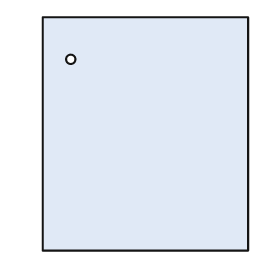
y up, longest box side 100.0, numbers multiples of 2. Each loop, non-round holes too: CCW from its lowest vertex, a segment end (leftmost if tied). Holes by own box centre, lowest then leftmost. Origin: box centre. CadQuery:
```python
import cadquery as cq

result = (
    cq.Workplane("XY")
    .moveTo(-44.0, -50.0)
    .lineTo(44.0, -50.0)
    .lineTo(44.0, 50.0)
    .lineTo(-44.0, 50.0)
    .close()
    .moveTo(-32.0, 32.0)
    .circle(2.0)
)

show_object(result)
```